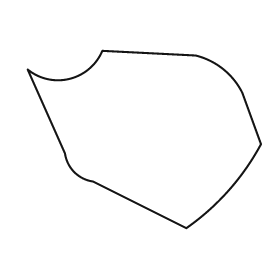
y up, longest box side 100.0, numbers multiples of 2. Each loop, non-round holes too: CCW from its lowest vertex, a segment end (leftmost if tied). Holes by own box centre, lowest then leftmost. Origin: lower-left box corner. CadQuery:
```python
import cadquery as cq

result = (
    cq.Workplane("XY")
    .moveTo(68.0, 0.0)
    .threePointArc((86.0, 16.0), (100.0, 36.0))
    .lineTo(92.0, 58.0)
    .threePointArc((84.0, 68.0), (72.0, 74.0))
    .lineTo(32.0, 76.0)
    .threePointArc((18.0, 64.0), (0.0, 68.0))
    .lineTo(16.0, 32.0)
    .threePointArc((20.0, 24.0), (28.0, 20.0))
    .close()
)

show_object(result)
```